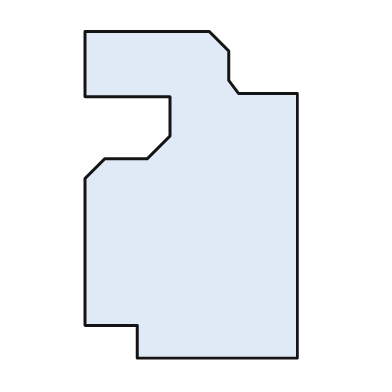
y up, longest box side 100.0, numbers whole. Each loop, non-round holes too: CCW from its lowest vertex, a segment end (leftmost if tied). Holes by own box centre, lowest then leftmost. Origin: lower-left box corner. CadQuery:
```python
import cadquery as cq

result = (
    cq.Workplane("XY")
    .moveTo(16.0, 0.0)
    .lineTo(65.0, 0.0)
    .lineTo(65.0, 81.0)
    .lineTo(47.0, 81.0)
    .lineTo(44.0, 85.0)
    .lineTo(44.0, 94.0)
    .lineTo(38.0, 100.0)
    .lineTo(0.0, 100.0)
    .lineTo(0.0, 80.0)
    .lineTo(26.0, 80.0)
    .lineTo(26.0, 68.0)
    .lineTo(19.0, 61.0)
    .lineTo(6.0, 61.0)
    .lineTo(0.0, 55.0)
    .lineTo(0.0, 10.0)
    .lineTo(16.0, 10.0)
    .close()
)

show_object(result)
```